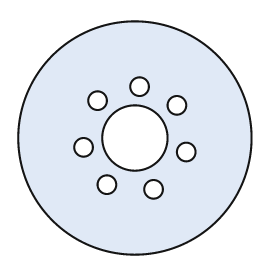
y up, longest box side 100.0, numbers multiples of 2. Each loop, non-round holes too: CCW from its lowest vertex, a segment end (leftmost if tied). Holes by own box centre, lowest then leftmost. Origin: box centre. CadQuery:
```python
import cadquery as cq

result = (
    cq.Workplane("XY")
    .moveTo(0.0, 0.0)
    .circle(50.0)
    .moveTo(8.0, -22.0)
    .circle(4.0)
    .moveTo(-12.0, -20.0)
    .circle(4.0)
    .moveTo(22.0, -6.0)
    .circle(4.0)
    .moveTo(-22.0, -4.0)
    .circle(4.0)
    .moveTo(0.0, 0.0)
    .circle(14.0)
    .moveTo(18.0, 14.0)
    .circle(4.0)
    .moveTo(-16.0, 16.0)
    .circle(4.0)
    .moveTo(2.0, 22.0)
    .circle(4.0)
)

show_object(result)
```